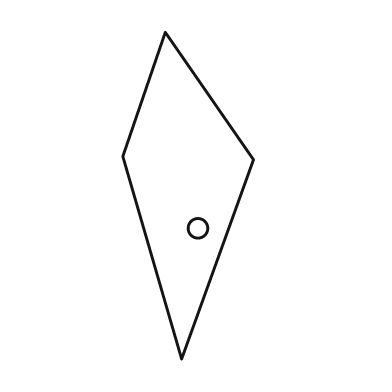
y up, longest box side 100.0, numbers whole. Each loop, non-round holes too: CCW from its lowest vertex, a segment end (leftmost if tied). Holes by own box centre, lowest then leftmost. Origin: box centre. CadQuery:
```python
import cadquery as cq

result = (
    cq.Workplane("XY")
    .moveTo(-2.0, -50.0)
    .lineTo(20.0, 11.0)
    .lineTo(-7.0, 50.0)
    .lineTo(-20.0, 12.0)
    .close()
    .moveTo(3.0, -10.0)
    .circle(3.0)
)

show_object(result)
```